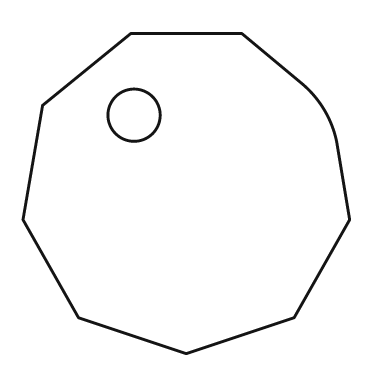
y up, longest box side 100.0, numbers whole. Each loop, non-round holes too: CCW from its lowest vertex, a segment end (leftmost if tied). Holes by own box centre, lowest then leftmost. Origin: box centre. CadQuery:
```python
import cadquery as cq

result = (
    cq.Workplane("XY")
    .moveTo(0.0, -49.0)
    .lineTo(33.0, -38.0)
    .lineTo(50.0, -8.0)
    .lineTo(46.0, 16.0)
    .threePointArc((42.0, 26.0), (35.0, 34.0))
    .lineTo(17.0, 49.0)
    .lineTo(-17.0, 49.0)
    .lineTo(-44.0, 27.0)
    .lineTo(-50.0, -8.0)
    .lineTo(-33.0, -38.0)
    .close()
    .moveTo(-16.0, 24.0)
    .circle(8.0)
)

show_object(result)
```